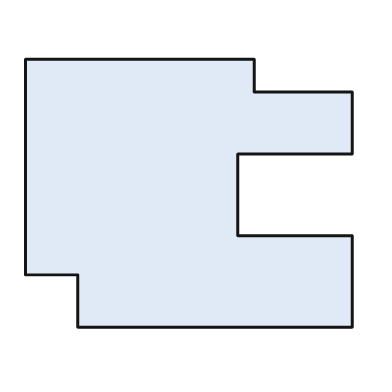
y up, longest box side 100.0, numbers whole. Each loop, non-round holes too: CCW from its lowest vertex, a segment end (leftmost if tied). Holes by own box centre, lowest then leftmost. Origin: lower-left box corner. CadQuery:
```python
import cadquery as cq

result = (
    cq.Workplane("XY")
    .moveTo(16.0, 0.0)
    .lineTo(100.0, 0.0)
    .lineTo(100.0, 28.0)
    .lineTo(65.0, 28.0)
    .lineTo(65.0, 53.0)
    .lineTo(100.0, 53.0)
    .lineTo(100.0, 72.0)
    .lineTo(70.0, 72.0)
    .lineTo(70.0, 82.0)
    .lineTo(0.0, 82.0)
    .lineTo(0.0, 16.0)
    .lineTo(16.0, 16.0)
    .close()
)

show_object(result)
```